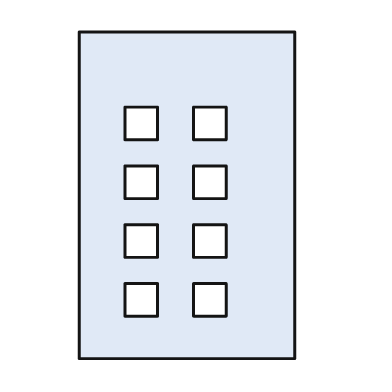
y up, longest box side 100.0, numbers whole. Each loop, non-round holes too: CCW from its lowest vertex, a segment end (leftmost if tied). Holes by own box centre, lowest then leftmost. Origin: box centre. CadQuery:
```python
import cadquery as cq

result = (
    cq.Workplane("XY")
    .moveTo(-33.0, -50.0)
    .lineTo(33.0, -50.0)
    .lineTo(33.0, 50.0)
    .lineTo(-33.0, 50.0)
    .close()
    .moveTo(-19.0, -37.0)
    .lineTo(-9.0, -37.0)
    .lineTo(-9.0, -27.0)
    .lineTo(-19.0, -27.0)
    .close()
    .moveTo(2.0, -37.0)
    .lineTo(12.0, -37.0)
    .lineTo(12.0, -27.0)
    .lineTo(2.0, -27.0)
    .close()
    .moveTo(-19.0, -19.0)
    .lineTo(-9.0, -19.0)
    .lineTo(-9.0, -9.0)
    .lineTo(-19.0, -9.0)
    .close()
    .moveTo(2.0, -19.0)
    .lineTo(12.0, -19.0)
    .lineTo(12.0, -9.0)
    .lineTo(2.0, -9.0)
    .close()
    .moveTo(-19.0, -1.0)
    .lineTo(-9.0, -1.0)
    .lineTo(-9.0, 9.0)
    .lineTo(-19.0, 9.0)
    .close()
    .moveTo(2.0, -1.0)
    .lineTo(12.0, -1.0)
    .lineTo(12.0, 9.0)
    .lineTo(2.0, 9.0)
    .close()
    .moveTo(-19.0, 17.0)
    .lineTo(-9.0, 17.0)
    .lineTo(-9.0, 27.0)
    .lineTo(-19.0, 27.0)
    .close()
    .moveTo(2.0, 17.0)
    .lineTo(12.0, 17.0)
    .lineTo(12.0, 27.0)
    .lineTo(2.0, 27.0)
    .close()
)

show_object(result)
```